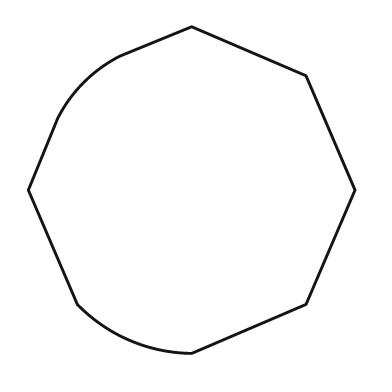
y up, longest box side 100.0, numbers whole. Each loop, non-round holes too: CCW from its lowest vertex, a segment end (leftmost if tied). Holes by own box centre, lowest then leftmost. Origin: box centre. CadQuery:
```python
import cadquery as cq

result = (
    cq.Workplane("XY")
    .moveTo(0.0, -50.0)
    .lineTo(35.0, -35.0)
    .lineTo(50.0, 0.0)
    .lineTo(35.0, 35.0)
    .lineTo(0.0, 50.0)
    .lineTo(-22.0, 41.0)
    .threePointArc((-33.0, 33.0), (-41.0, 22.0))
    .lineTo(-50.0, 0.0)
    .lineTo(-35.0, -35.0)
    .threePointArc((-19.0, -46.0), (0.0, -50.0))
    .close()
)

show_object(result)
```